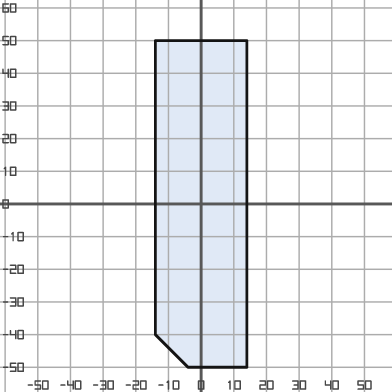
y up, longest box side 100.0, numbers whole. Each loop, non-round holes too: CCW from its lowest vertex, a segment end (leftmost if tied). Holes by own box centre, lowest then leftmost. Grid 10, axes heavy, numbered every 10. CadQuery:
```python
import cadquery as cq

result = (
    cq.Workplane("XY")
    .moveTo(-4.0, -50.0)
    .lineTo(14.0, -50.0)
    .lineTo(14.0, 50.0)
    .lineTo(-14.0, 50.0)
    .lineTo(-14.0, -40.0)
    .close()
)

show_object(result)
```